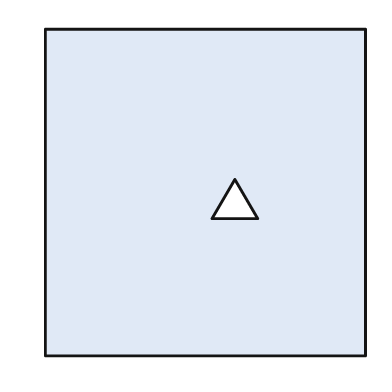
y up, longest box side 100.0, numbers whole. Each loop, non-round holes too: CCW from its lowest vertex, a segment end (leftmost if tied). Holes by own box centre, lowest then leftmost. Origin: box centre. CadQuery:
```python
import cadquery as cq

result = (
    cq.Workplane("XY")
    .moveTo(-49.0, -50.0)
    .lineTo(49.0, -50.0)
    .lineTo(49.0, 50.0)
    .lineTo(-49.0, 50.0)
    .close()
    .moveTo(2.0, -8.0)
    .lineTo(16.0, -8.0)
    .lineTo(9.0, 4.0)
    .close()
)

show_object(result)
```